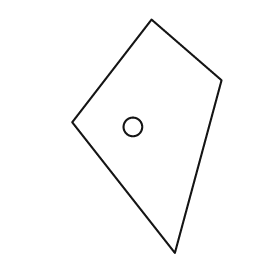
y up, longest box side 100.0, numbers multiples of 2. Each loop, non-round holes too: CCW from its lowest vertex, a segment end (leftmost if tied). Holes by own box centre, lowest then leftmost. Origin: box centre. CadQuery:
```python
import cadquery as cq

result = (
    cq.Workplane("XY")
    .moveTo(12.0, -50.0)
    .lineTo(32.0, 24.0)
    .lineTo(2.0, 50.0)
    .lineTo(-32.0, 6.0)
    .close()
    .moveTo(-6.0, 4.0)
    .circle(4.0)
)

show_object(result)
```